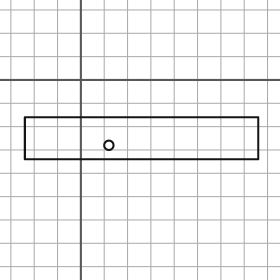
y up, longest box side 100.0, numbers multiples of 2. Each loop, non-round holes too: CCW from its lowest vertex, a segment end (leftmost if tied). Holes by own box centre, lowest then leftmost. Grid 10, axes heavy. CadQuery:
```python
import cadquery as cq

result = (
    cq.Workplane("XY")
    .moveTo(-24.0, -34.0)
    .lineTo(76.0, -34.0)
    .lineTo(76.0, -16.0)
    .lineTo(-24.0, -16.0)
    .close()
    .moveTo(12.0, -28.0)
    .circle(2.0)
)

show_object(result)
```